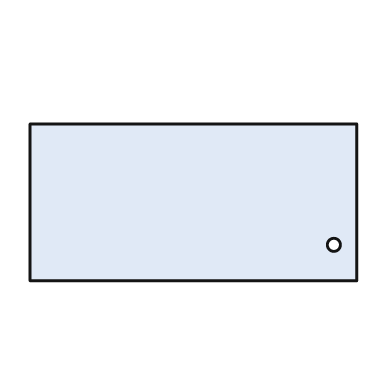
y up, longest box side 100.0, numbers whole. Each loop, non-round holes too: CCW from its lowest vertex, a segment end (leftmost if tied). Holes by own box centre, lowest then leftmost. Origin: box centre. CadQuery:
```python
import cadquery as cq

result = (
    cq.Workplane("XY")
    .moveTo(-50.0, -24.0)
    .lineTo(50.0, -24.0)
    .lineTo(50.0, 24.0)
    .lineTo(-50.0, 24.0)
    .close()
    .moveTo(43.0, -13.0)
    .circle(2.0)
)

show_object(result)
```